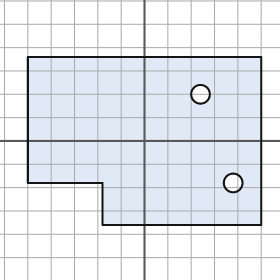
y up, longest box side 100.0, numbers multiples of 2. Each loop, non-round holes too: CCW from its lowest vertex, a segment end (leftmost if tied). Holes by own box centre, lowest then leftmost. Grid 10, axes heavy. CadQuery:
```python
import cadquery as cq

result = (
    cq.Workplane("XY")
    .moveTo(-18.0, -36.0)
    .lineTo(50.0, -36.0)
    .lineTo(50.0, 36.0)
    .lineTo(-50.0, 36.0)
    .lineTo(-50.0, -18.0)
    .lineTo(-18.0, -18.0)
    .close()
    .moveTo(38.0, -18.0)
    .circle(4.0)
    .moveTo(24.0, 20.0)
    .circle(4.0)
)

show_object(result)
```